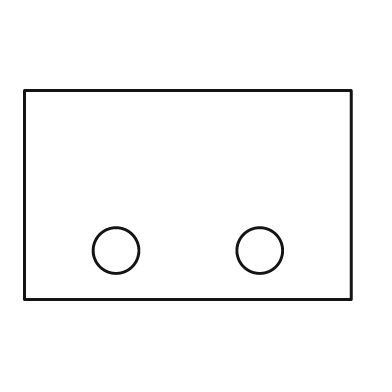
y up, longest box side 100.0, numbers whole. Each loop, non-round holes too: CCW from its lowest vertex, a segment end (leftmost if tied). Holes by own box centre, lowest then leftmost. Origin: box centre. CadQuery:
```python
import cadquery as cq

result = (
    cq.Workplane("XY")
    .moveTo(-50.0, -32.0)
    .lineTo(50.0, -32.0)
    .lineTo(50.0, 32.0)
    .lineTo(-50.0, 32.0)
    .close()
    .moveTo(-22.0, -17.0)
    .circle(7.0)
    .moveTo(22.0, -17.0)
    .circle(7.0)
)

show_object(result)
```